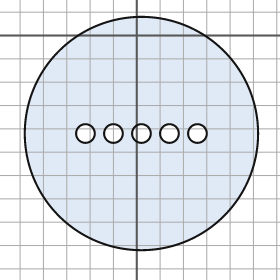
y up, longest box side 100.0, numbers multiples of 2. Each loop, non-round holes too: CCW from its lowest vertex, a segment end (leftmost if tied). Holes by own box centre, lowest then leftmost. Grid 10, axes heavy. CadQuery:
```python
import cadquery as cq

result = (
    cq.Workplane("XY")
    .moveTo(2.0, -42.0)
    .circle(50.0)
    .moveTo(-22.0, -42.0)
    .circle(4.0)
    .moveTo(-10.0, -42.0)
    .circle(4.0)
    .moveTo(2.0, -42.0)
    .circle(4.0)
    .moveTo(14.0, -42.0)
    .circle(4.0)
    .moveTo(26.0, -42.0)
    .circle(4.0)
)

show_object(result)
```